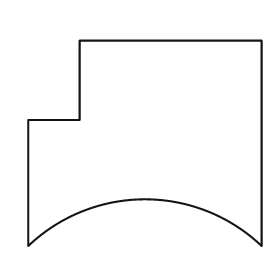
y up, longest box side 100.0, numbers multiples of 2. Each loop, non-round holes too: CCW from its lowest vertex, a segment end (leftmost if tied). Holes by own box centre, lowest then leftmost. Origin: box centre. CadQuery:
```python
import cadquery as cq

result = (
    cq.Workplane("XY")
    .moveTo(-50.0, -44.0)
    .threePointArc((0.0, -24.0), (50.0, -44.0))
    .lineTo(50.0, 44.0)
    .lineTo(-28.0, 44.0)
    .lineTo(-28.0, 10.0)
    .lineTo(-50.0, 10.0)
    .close()
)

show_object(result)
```